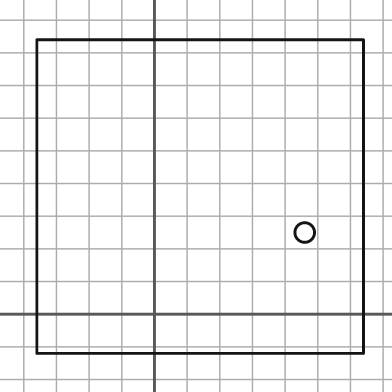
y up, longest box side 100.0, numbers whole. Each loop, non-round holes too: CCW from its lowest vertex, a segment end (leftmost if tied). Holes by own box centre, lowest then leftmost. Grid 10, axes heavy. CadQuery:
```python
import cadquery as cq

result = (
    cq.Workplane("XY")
    .moveTo(-36.0, -12.0)
    .lineTo(64.0, -12.0)
    .lineTo(64.0, 84.0)
    .lineTo(-36.0, 84.0)
    .close()
    .moveTo(46.0, 25.0)
    .circle(3.0)
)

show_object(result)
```